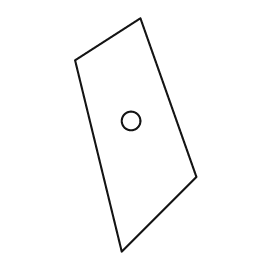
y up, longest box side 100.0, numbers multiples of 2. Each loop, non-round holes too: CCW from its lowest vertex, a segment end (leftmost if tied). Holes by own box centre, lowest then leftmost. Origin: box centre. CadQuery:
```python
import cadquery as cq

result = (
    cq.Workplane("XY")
    .moveTo(-6.0, -50.0)
    .lineTo(26.0, -18.0)
    .lineTo(2.0, 50.0)
    .lineTo(-26.0, 32.0)
    .close()
    .moveTo(-2.0, 6.0)
    .circle(4.0)
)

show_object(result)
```